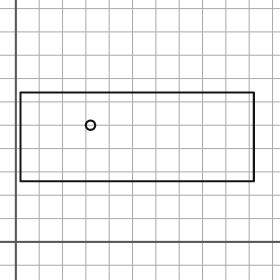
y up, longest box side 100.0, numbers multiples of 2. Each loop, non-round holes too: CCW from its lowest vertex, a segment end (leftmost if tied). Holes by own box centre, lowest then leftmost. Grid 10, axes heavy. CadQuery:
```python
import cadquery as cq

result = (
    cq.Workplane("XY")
    .moveTo(2.0, 26.0)
    .lineTo(102.0, 26.0)
    .lineTo(102.0, 64.0)
    .lineTo(2.0, 64.0)
    .close()
    .moveTo(32.0, 50.0)
    .circle(2.0)
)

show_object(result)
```